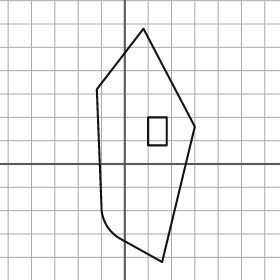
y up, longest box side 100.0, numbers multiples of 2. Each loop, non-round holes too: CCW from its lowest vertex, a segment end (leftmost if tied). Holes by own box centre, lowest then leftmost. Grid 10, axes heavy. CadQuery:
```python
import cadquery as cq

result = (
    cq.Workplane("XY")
    .moveTo(16.0, -42.0)
    .lineTo(30.0, 16.0)
    .lineTo(8.0, 58.0)
    .lineTo(-12.0, 32.0)
    .lineTo(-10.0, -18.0)
    .threePointArc((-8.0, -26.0), (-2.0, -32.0))
    .close()
    .moveTo(10.0, 8.0)
    .lineTo(18.0, 8.0)
    .lineTo(18.0, 20.0)
    .lineTo(10.0, 20.0)
    .close()
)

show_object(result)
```